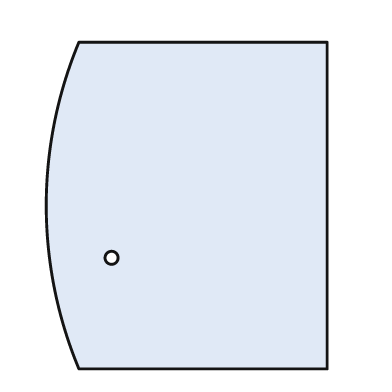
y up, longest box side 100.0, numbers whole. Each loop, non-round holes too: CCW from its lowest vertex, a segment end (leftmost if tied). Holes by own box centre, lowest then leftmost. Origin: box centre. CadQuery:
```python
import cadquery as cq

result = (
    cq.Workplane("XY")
    .moveTo(-33.0, -50.0)
    .lineTo(43.0, -50.0)
    .lineTo(43.0, 50.0)
    .lineTo(-33.0, 50.0)
    .threePointArc((-43.0, 0.0), (-33.0, -50.0))
    .close()
    .moveTo(-23.0, -16.0)
    .circle(2.0)
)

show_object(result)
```